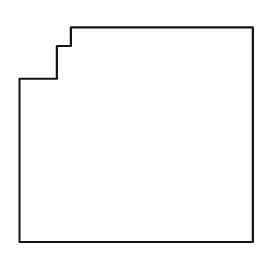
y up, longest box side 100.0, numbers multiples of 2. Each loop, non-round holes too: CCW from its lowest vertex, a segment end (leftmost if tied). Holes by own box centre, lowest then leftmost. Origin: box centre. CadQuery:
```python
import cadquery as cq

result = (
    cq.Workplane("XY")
    .moveTo(-50.0, -46.0)
    .lineTo(50.0, -46.0)
    .lineTo(50.0, 46.0)
    .lineTo(-28.0, 46.0)
    .lineTo(-28.0, 38.0)
    .lineTo(-34.0, 38.0)
    .lineTo(-34.0, 24.0)
    .lineTo(-50.0, 24.0)
    .close()
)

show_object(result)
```